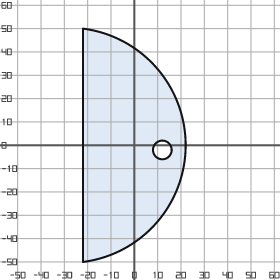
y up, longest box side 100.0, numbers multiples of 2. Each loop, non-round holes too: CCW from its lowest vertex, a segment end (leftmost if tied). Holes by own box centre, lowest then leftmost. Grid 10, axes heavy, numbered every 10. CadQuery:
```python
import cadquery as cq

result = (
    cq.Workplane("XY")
    .moveTo(-22.0, -50.0)
    .threePointArc((22.0, 0.0), (-22.0, 50.0))
    .close()
    .moveTo(12.0, -2.0)
    .circle(4.0)
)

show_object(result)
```